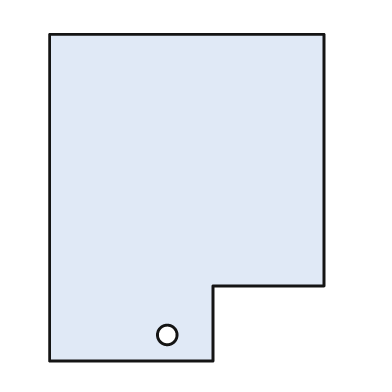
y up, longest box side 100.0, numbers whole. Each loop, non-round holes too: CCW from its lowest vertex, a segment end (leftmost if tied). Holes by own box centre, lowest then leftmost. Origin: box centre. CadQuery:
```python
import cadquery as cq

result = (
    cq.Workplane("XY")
    .moveTo(-42.0, -50.0)
    .lineTo(8.0, -50.0)
    .lineTo(8.0, -27.0)
    .lineTo(42.0, -27.0)
    .lineTo(42.0, 50.0)
    .lineTo(-42.0, 50.0)
    .close()
    .moveTo(-6.0, -42.0)
    .circle(3.0)
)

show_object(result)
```